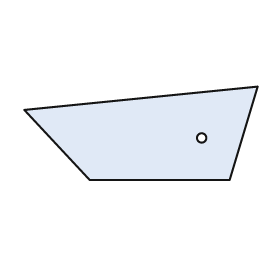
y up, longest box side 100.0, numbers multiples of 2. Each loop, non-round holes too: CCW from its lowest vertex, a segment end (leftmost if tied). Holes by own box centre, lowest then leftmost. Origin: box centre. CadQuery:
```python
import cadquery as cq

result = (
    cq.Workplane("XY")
    .moveTo(-22.0, -20.0)
    .lineTo(38.0, -20.0)
    .lineTo(50.0, 20.0)
    .lineTo(-50.0, 10.0)
    .close()
    .moveTo(26.0, -2.0)
    .circle(2.0)
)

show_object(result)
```